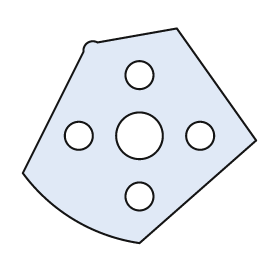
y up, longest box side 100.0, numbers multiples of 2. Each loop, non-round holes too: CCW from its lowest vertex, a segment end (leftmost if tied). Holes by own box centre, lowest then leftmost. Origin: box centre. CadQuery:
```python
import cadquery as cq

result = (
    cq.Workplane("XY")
    .moveTo(0.0, -46.0)
    .lineTo(50.0, -2.0)
    .lineTo(16.0, 46.0)
    .lineTo(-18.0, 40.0)
    .threePointArc((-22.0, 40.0), (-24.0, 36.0))
    .lineTo(-50.0, -16.0)
    .threePointArc((-28.0, -36.0), (0.0, -46.0))
    .close()
    .moveTo(0.0, -26.0)
    .circle(6.0)
    .moveTo(-26.0, 0.0)
    .circle(6.0)
    .moveTo(0.0, 0.0)
    .circle(10.0)
    .moveTo(26.0, 0.0)
    .circle(6.0)
    .moveTo(0.0, 26.0)
    .circle(6.0)
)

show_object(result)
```